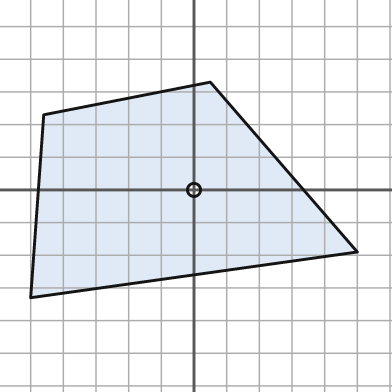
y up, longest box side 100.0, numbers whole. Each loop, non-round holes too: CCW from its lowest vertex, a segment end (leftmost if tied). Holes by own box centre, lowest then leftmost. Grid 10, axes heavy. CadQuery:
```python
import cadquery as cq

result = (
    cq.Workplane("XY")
    .moveTo(-50.0, -33.0)
    .lineTo(50.0, -19.0)
    .lineTo(5.0, 33.0)
    .lineTo(-46.0, 23.0)
    .close()
    .moveTo(0.0, 0.0)
    .circle(2.0)
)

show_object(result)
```